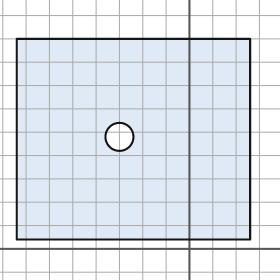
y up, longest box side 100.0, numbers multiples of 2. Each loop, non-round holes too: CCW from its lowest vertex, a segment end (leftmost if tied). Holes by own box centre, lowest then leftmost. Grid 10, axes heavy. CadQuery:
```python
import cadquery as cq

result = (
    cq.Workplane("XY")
    .moveTo(-74.0, 4.0)
    .lineTo(26.0, 4.0)
    .lineTo(26.0, 90.0)
    .lineTo(-74.0, 90.0)
    .close()
    .moveTo(-30.0, 48.0)
    .circle(6.0)
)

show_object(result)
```